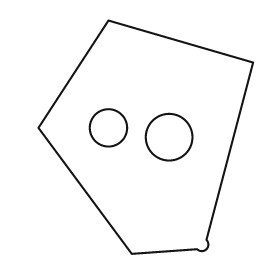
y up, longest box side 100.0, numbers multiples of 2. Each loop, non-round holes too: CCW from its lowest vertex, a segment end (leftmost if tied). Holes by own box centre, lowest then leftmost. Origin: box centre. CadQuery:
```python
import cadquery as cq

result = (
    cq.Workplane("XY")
    .moveTo(-6.0, -50.0)
    .lineTo(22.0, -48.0)
    .threePointArc((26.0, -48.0), (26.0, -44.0))
    .lineTo(46.0, 32.0)
    .lineTo(-16.0, 50.0)
    .lineTo(-46.0, 4.0)
    .close()
    .moveTo(10.0, 0.0)
    .circle(10.0)
    .moveTo(-16.0, 4.0)
    .circle(8.0)
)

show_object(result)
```